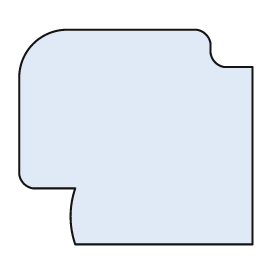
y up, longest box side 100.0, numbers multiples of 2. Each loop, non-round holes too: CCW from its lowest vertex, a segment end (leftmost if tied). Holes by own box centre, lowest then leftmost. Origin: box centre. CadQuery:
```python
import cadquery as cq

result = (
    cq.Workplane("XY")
    .moveTo(-26.0, -46.0)
    .lineTo(50.0, -46.0)
    .lineTo(50.0, 30.0)
    .lineTo(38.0, 30.0)
    .threePointArc((34.0, 32.0), (32.0, 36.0))
    .lineTo(32.0, 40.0)
    .threePointArc((30.0, 44.0), (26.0, 46.0))
    .lineTo(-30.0, 46.0)
    .threePointArc((-44.0, 40.0), (-50.0, 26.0))
    .lineTo(-50.0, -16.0)
    .threePointArc((-48.0, -20.0), (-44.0, -22.0))
    .lineTo(-26.0, -22.0)
    .threePointArc((-28.0, -34.0), (-26.0, -46.0))
    .close()
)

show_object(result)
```